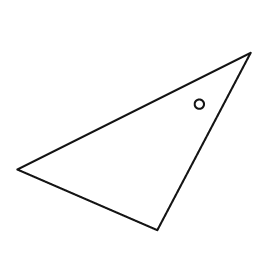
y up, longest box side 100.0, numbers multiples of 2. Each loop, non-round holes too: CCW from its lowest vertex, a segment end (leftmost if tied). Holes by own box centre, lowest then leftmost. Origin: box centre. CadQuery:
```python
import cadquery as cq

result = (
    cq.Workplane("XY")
    .moveTo(10.0, -38.0)
    .lineTo(50.0, 38.0)
    .lineTo(-50.0, -12.0)
    .close()
    .moveTo(28.0, 16.0)
    .circle(2.0)
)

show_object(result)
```